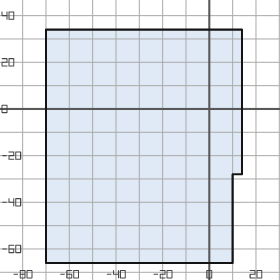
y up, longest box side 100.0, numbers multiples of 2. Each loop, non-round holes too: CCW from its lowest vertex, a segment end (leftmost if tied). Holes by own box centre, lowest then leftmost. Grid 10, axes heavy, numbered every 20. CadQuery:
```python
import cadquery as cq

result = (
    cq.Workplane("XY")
    .moveTo(-70.0, -66.0)
    .lineTo(10.0, -66.0)
    .lineTo(10.0, -28.0)
    .lineTo(14.0, -28.0)
    .lineTo(14.0, 34.0)
    .lineTo(-70.0, 34.0)
    .close()
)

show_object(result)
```